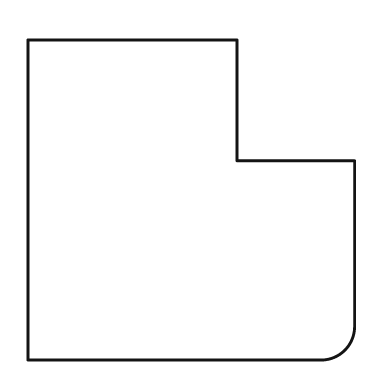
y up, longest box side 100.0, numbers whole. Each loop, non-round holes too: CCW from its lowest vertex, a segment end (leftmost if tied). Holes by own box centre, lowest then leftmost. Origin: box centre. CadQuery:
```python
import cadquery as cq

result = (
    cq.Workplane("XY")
    .moveTo(-50.0, -49.0)
    .lineTo(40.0, -49.0)
    .threePointArc((47.0, -46.0), (50.0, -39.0))
    .lineTo(50.0, 12.0)
    .lineTo(14.0, 12.0)
    .lineTo(14.0, 49.0)
    .lineTo(-50.0, 49.0)
    .close()
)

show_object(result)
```